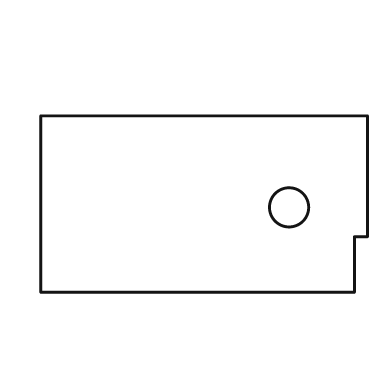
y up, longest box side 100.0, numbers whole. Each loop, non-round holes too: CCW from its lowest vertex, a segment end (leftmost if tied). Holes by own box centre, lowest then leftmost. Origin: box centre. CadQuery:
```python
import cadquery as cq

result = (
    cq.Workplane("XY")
    .moveTo(-50.0, -27.0)
    .lineTo(46.0, -27.0)
    .lineTo(46.0, -10.0)
    .lineTo(50.0, -10.0)
    .lineTo(50.0, 27.0)
    .lineTo(-50.0, 27.0)
    .close()
    .moveTo(26.0, -1.0)
    .circle(6.0)
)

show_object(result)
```